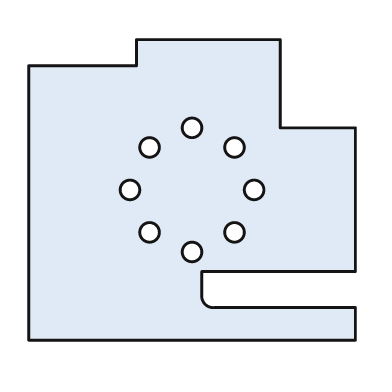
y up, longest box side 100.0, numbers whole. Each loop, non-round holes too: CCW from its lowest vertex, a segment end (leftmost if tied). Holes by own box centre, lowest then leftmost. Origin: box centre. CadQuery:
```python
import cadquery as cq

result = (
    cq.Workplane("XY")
    .moveTo(-50.0, -46.0)
    .lineTo(50.0, -46.0)
    .lineTo(50.0, -36.0)
    .lineTo(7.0, -36.0)
    .threePointArc((4.0, -35.0), (3.0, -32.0))
    .lineTo(3.0, -25.0)
    .lineTo(50.0, -25.0)
    .lineTo(50.0, 19.0)
    .lineTo(27.0, 19.0)
    .lineTo(27.0, 46.0)
    .lineTo(-17.0, 46.0)
    .lineTo(-17.0, 38.0)
    .lineTo(-50.0, 38.0)
    .close()
    .moveTo(0.0, -19.0)
    .circle(3.0)
    .moveTo(-13.0, -13.0)
    .circle(3.0)
    .moveTo(13.0, -13.0)
    .circle(3.0)
    .moveTo(-19.0, 0.0)
    .circle(3.0)
    .moveTo(19.0, 0.0)
    .circle(3.0)
    .moveTo(-13.0, 13.0)
    .circle(3.0)
    .moveTo(13.0, 13.0)
    .circle(3.0)
    .moveTo(0.0, 19.0)
    .circle(3.0)
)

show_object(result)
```